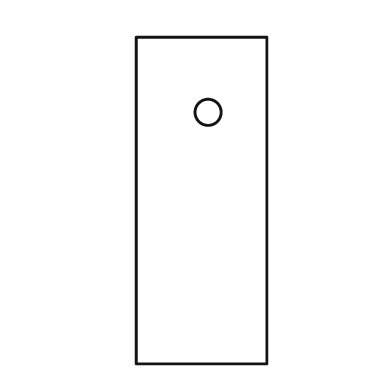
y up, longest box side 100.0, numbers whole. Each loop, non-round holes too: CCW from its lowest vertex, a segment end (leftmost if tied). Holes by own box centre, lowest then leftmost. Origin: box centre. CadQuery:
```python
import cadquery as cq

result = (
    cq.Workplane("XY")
    .moveTo(-20.0, -50.0)
    .lineTo(20.0, -50.0)
    .lineTo(20.0, 50.0)
    .lineTo(-20.0, 50.0)
    .close()
    .moveTo(2.0, 27.0)
    .circle(4.0)
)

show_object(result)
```